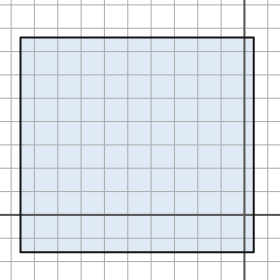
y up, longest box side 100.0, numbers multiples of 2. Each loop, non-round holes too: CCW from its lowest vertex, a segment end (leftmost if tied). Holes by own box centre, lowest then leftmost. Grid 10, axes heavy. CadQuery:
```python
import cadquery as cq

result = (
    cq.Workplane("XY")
    .moveTo(-96.0, -16.0)
    .lineTo(4.0, -16.0)
    .lineTo(4.0, 76.0)
    .lineTo(-96.0, 76.0)
    .close()
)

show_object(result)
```